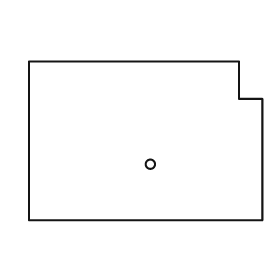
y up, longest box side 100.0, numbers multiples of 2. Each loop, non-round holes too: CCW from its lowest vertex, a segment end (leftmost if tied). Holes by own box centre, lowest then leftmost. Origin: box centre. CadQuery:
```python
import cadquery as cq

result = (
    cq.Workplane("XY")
    .moveTo(-50.0, -34.0)
    .lineTo(50.0, -34.0)
    .lineTo(50.0, 18.0)
    .lineTo(40.0, 18.0)
    .lineTo(40.0, 34.0)
    .lineTo(-50.0, 34.0)
    .close()
    .moveTo(2.0, -10.0)
    .circle(2.0)
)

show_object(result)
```